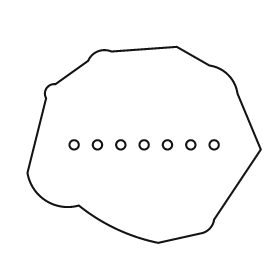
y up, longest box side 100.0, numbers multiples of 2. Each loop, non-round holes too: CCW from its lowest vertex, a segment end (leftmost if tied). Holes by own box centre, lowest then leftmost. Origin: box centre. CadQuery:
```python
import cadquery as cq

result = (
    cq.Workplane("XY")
    .moveTo(6.0, -42.0)
    .lineTo(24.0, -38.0)
    .threePointArc((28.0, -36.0), (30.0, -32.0))
    .lineTo(50.0, -2.0)
    .lineTo(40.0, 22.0)
    .threePointArc((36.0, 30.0), (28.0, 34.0))
    .lineTo(14.0, 42.0)
    .lineTo(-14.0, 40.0)
    .threePointArc((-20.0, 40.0), (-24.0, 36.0))
    .lineTo(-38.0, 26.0)
    .threePointArc((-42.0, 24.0), (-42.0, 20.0))
    .lineTo(-50.0, -12.0)
    .threePointArc((-42.0, -24.0), (-28.0, -26.0))
    .threePointArc((-12.0, -36.0), (6.0, -42.0))
    .close()
    .moveTo(-30.0, 0.0)
    .circle(2.0)
    .moveTo(-20.0, 0.0)
    .circle(2.0)
    .moveTo(-10.0, 0.0)
    .circle(2.0)
    .moveTo(0.0, 0.0)
    .circle(2.0)
    .moveTo(10.0, 0.0)
    .circle(2.0)
    .moveTo(20.0, 0.0)
    .circle(2.0)
    .moveTo(30.0, 0.0)
    .circle(2.0)
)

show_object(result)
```